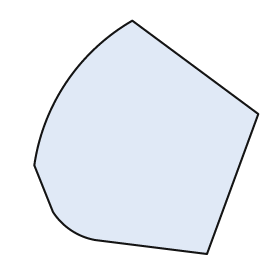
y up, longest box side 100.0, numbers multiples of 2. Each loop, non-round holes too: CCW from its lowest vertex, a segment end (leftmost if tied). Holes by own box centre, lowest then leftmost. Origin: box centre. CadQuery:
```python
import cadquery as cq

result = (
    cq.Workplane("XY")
    .moveTo(26.0, -50.0)
    .lineTo(48.0, 10.0)
    .lineTo(-6.0, 50.0)
    .threePointArc((-34.0, 24.0), (-48.0, -12.0))
    .lineTo(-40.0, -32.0)
    .threePointArc((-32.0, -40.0), (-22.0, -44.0))
    .close()
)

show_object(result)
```